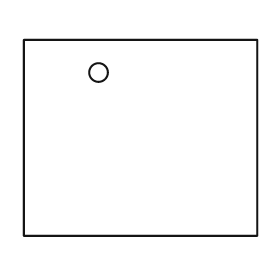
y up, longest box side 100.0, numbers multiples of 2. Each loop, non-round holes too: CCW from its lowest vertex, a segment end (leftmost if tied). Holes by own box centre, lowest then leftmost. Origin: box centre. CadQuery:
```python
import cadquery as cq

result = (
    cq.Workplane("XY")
    .moveTo(-50.0, -42.0)
    .lineTo(50.0, -42.0)
    .lineTo(50.0, 42.0)
    .lineTo(-50.0, 42.0)
    .close()
    .moveTo(-18.0, 28.0)
    .circle(4.0)
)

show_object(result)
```